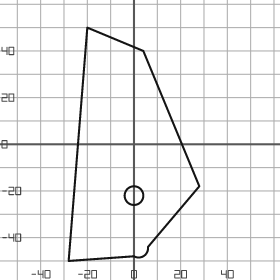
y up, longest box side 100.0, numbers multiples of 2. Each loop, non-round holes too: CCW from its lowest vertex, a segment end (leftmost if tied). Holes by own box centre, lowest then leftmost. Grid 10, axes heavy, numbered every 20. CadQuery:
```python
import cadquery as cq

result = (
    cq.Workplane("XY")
    .moveTo(-28.0, -50.0)
    .lineTo(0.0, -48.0)
    .threePointArc((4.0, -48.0), (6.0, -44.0))
    .lineTo(28.0, -18.0)
    .lineTo(4.0, 40.0)
    .lineTo(-20.0, 50.0)
    .close()
    .moveTo(0.0, -22.0)
    .circle(4.0)
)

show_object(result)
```